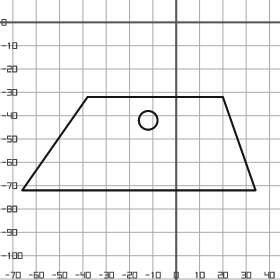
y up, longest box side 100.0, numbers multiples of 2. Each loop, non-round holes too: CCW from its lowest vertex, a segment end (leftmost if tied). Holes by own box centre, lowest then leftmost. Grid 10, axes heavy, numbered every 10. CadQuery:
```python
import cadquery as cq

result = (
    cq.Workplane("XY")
    .moveTo(-66.0, -72.0)
    .lineTo(34.0, -72.0)
    .lineTo(20.0, -32.0)
    .lineTo(-38.0, -32.0)
    .close()
    .moveTo(-12.0, -42.0)
    .circle(4.0)
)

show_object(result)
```